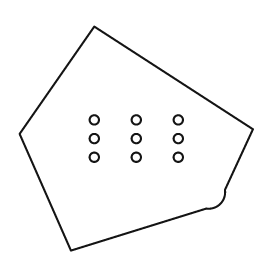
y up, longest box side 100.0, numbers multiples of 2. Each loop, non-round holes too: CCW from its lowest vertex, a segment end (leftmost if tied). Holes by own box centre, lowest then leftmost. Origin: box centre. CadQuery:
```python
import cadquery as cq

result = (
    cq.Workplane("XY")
    .moveTo(-28.0, -48.0)
    .lineTo(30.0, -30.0)
    .threePointArc((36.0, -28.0), (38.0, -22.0))
    .lineTo(50.0, 4.0)
    .lineTo(-18.0, 48.0)
    .lineTo(-50.0, 2.0)
    .close()
    .moveTo(-18.0, -8.0)
    .circle(2.0)
    .moveTo(0.0, -8.0)
    .circle(2.0)
    .moveTo(18.0, -8.0)
    .circle(2.0)
    .moveTo(-18.0, 0.0)
    .circle(2.0)
    .moveTo(0.0, 0.0)
    .circle(2.0)
    .moveTo(18.0, 0.0)
    .circle(2.0)
    .moveTo(-18.0, 8.0)
    .circle(2.0)
    .moveTo(0.0, 8.0)
    .circle(2.0)
    .moveTo(18.0, 8.0)
    .circle(2.0)
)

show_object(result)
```